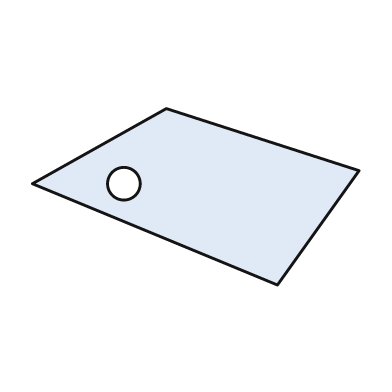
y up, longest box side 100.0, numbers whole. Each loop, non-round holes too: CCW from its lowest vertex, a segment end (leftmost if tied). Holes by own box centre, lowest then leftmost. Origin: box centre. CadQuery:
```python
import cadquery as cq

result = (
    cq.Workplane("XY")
    .moveTo(25.0, -27.0)
    .lineTo(50.0, 8.0)
    .lineTo(-9.0, 27.0)
    .lineTo(-50.0, 4.0)
    .close()
    .moveTo(-22.0, 4.0)
    .circle(5.0)
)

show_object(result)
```